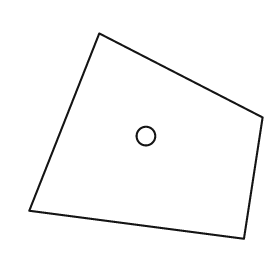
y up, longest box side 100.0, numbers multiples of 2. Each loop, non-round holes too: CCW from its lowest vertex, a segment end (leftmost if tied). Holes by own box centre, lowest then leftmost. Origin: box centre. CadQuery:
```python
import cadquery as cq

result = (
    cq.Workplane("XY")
    .moveTo(42.0, -44.0)
    .lineTo(50.0, 8.0)
    .lineTo(-20.0, 44.0)
    .lineTo(-50.0, -32.0)
    .close()
    .moveTo(0.0, 0.0)
    .circle(4.0)
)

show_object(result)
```